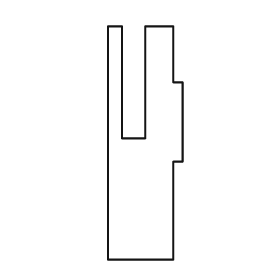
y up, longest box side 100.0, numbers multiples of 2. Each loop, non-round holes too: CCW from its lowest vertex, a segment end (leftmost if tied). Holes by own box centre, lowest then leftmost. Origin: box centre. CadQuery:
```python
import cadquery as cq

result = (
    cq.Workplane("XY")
    .moveTo(-16.0, -50.0)
    .lineTo(12.0, -50.0)
    .lineTo(12.0, -8.0)
    .lineTo(16.0, -8.0)
    .lineTo(16.0, 26.0)
    .lineTo(12.0, 26.0)
    .lineTo(12.0, 50.0)
    .lineTo(0.0, 50.0)
    .lineTo(0.0, 2.0)
    .lineTo(-10.0, 2.0)
    .lineTo(-10.0, 50.0)
    .lineTo(-16.0, 50.0)
    .close()
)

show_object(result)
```